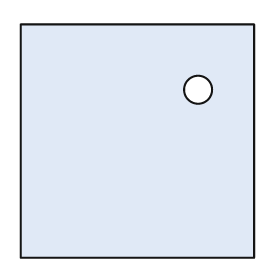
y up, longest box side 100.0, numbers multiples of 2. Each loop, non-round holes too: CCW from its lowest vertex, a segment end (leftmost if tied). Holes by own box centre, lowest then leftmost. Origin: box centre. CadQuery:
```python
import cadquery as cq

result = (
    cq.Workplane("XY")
    .moveTo(-50.0, -50.0)
    .lineTo(50.0, -50.0)
    .lineTo(50.0, 50.0)
    .lineTo(-50.0, 50.0)
    .close()
    .moveTo(26.0, 22.0)
    .circle(6.0)
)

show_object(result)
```